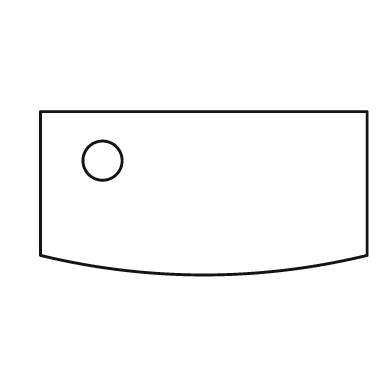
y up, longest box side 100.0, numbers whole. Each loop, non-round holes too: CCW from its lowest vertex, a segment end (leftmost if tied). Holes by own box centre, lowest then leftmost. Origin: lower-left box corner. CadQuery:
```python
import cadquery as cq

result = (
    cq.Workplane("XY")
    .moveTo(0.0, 6.0)
    .threePointArc((50.0, 0.0), (100.0, 6.0))
    .lineTo(100.0, 50.0)
    .lineTo(0.0, 50.0)
    .close()
    .moveTo(19.0, 35.0)
    .circle(6.0)
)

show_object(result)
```